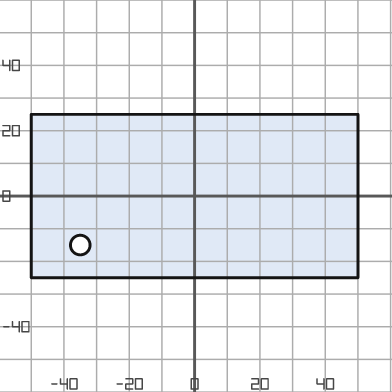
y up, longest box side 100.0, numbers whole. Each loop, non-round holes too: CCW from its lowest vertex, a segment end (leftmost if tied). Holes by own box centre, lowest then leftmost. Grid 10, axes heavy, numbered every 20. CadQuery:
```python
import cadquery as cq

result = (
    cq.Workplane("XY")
    .moveTo(-50.0, -25.0)
    .lineTo(50.0, -25.0)
    .lineTo(50.0, 25.0)
    .lineTo(-50.0, 25.0)
    .close()
    .moveTo(-35.0, -15.0)
    .circle(3.0)
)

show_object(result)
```